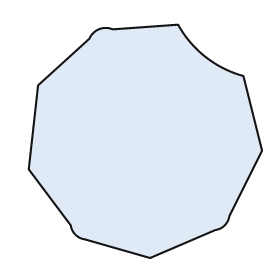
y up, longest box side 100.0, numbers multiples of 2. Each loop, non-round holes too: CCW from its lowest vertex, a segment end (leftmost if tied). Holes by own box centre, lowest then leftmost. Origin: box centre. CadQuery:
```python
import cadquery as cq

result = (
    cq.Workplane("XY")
    .moveTo(2.0, -50.0)
    .lineTo(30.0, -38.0)
    .threePointArc((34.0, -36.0), (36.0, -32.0))
    .lineTo(50.0, -4.0)
    .lineTo(42.0, 28.0)
    .threePointArc((26.0, 36.0), (14.0, 50.0))
    .lineTo(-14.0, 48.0)
    .threePointArc((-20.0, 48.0), (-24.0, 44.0))
    .lineTo(-46.0, 24.0)
    .lineTo(-50.0, -12.0)
    .lineTo(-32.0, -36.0)
    .threePointArc((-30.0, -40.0), (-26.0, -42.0))
    .close()
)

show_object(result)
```